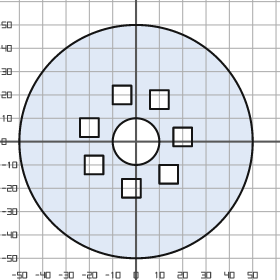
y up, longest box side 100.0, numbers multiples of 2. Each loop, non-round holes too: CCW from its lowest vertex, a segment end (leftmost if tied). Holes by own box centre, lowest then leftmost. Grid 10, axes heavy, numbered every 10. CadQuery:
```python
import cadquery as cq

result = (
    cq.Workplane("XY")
    .moveTo(0.0, 0.0)
    .circle(50.0)
    .moveTo(-6.0, -24.0)
    .lineTo(2.0, -24.0)
    .lineTo(2.0, -16.0)
    .lineTo(-6.0, -16.0)
    .close()
    .moveTo(10.0, -18.0)
    .lineTo(18.0, -18.0)
    .lineTo(18.0, -10.0)
    .lineTo(10.0, -10.0)
    .close()
    .moveTo(-22.0, -14.0)
    .lineTo(-14.0, -14.0)
    .lineTo(-14.0, -6.0)
    .lineTo(-22.0, -6.0)
    .close()
    .moveTo(0.0, 0.0)
    .circle(10.0)
    .moveTo(16.0, -2.0)
    .lineTo(24.0, -2.0)
    .lineTo(24.0, 6.0)
    .lineTo(16.0, 6.0)
    .close()
    .moveTo(-24.0, 2.0)
    .lineTo(-16.0, 2.0)
    .lineTo(-16.0, 10.0)
    .lineTo(-24.0, 10.0)
    .close()
    .moveTo(6.0, 14.0)
    .lineTo(14.0, 14.0)
    .lineTo(14.0, 22.0)
    .lineTo(6.0, 22.0)
    .close()
    .moveTo(-10.0, 16.0)
    .lineTo(-2.0, 16.0)
    .lineTo(-2.0, 24.0)
    .lineTo(-10.0, 24.0)
    .close()
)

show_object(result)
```